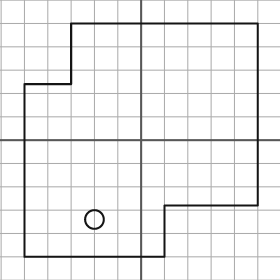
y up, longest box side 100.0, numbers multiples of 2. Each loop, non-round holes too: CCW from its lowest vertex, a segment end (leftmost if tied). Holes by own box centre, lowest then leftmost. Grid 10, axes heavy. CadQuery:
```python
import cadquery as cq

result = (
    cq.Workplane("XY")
    .moveTo(-50.0, -50.0)
    .lineTo(10.0, -50.0)
    .lineTo(10.0, -28.0)
    .lineTo(50.0, -28.0)
    .lineTo(50.0, 50.0)
    .lineTo(-30.0, 50.0)
    .lineTo(-30.0, 24.0)
    .lineTo(-50.0, 24.0)
    .close()
    .moveTo(-20.0, -34.0)
    .circle(4.0)
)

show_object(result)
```